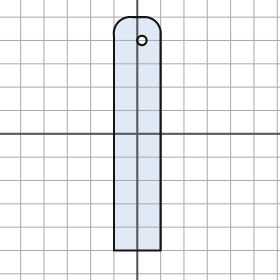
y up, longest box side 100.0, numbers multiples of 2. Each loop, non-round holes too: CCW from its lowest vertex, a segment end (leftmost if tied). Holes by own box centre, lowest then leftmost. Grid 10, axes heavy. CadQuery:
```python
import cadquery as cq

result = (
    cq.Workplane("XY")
    .moveTo(-10.0, -50.0)
    .lineTo(10.0, -50.0)
    .lineTo(10.0, 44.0)
    .threePointArc((8.0, 48.0), (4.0, 50.0))
    .lineTo(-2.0, 50.0)
    .threePointArc((-8.0, 48.0), (-10.0, 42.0))
    .close()
    .moveTo(2.0, 40.0)
    .circle(2.0)
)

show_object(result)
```